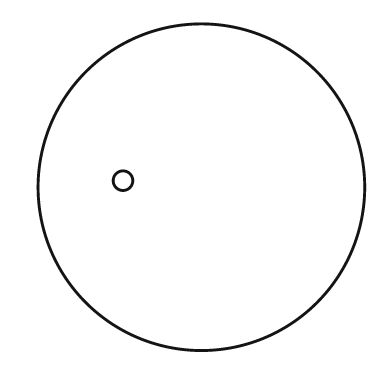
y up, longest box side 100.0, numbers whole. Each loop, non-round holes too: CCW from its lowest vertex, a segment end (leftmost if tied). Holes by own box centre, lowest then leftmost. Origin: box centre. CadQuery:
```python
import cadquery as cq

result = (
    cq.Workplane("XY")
    .moveTo(0.0, 0.0)
    .circle(50.0)
    .moveTo(-24.0, 2.0)
    .circle(3.0)
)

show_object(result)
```